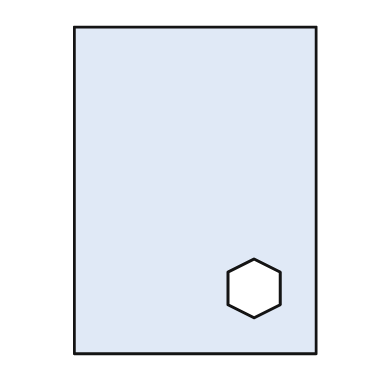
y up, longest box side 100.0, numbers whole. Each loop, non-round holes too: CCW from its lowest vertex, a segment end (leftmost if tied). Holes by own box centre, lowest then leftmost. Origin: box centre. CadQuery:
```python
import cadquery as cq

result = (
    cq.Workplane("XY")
    .moveTo(-37.0, -50.0)
    .lineTo(37.0, -50.0)
    .lineTo(37.0, 50.0)
    .lineTo(-37.0, 50.0)
    .close()
    .moveTo(18.0, -39.0)
    .lineTo(26.0, -35.0)
    .lineTo(26.0, -25.0)
    .lineTo(18.0, -21.0)
    .lineTo(10.0, -25.0)
    .lineTo(10.0, -35.0)
    .close()
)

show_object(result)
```